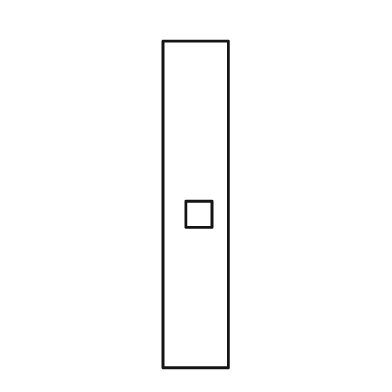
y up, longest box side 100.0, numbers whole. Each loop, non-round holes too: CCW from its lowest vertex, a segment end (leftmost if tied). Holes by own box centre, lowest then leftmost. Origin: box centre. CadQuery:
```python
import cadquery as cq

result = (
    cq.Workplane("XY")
    .moveTo(-10.0, -50.0)
    .lineTo(10.0, -50.0)
    .lineTo(10.0, 50.0)
    .lineTo(-10.0, 50.0)
    .close()
    .moveTo(-3.0, -7.0)
    .lineTo(5.0, -7.0)
    .lineTo(5.0, 1.0)
    .lineTo(-3.0, 1.0)
    .close()
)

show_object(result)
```